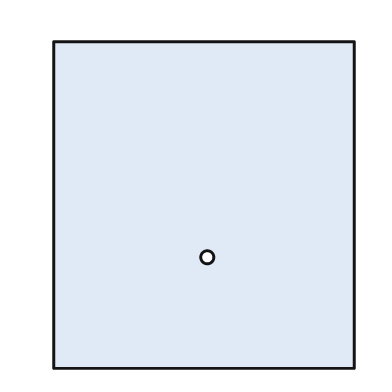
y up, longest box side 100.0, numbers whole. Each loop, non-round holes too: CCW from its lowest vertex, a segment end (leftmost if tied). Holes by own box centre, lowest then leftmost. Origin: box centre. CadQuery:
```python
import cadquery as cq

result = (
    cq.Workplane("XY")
    .moveTo(-46.0, -50.0)
    .lineTo(46.0, -50.0)
    .lineTo(46.0, 50.0)
    .lineTo(-46.0, 50.0)
    .close()
    .moveTo(1.0, -16.0)
    .circle(2.0)
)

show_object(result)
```